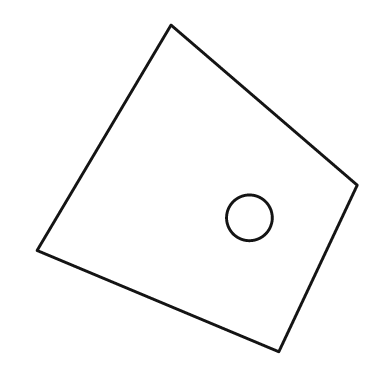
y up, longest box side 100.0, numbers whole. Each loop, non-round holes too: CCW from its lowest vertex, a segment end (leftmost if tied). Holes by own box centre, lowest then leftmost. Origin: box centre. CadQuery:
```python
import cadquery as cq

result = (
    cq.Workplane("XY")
    .moveTo(25.0, -50.0)
    .lineTo(49.0, 1.0)
    .lineTo(-8.0, 50.0)
    .lineTo(-49.0, -19.0)
    .close()
    .moveTo(16.0, -9.0)
    .circle(7.0)
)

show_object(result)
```